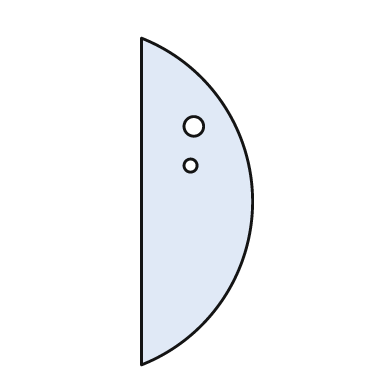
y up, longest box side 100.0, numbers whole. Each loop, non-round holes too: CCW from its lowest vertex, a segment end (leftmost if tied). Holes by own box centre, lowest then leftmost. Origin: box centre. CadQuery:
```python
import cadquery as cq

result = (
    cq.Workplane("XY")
    .moveTo(-17.0, -50.0)
    .threePointArc((17.0, 0.0), (-17.0, 50.0))
    .close()
    .moveTo(-2.0, 11.0)
    .circle(2.0)
    .moveTo(-1.0, 23.0)
    .circle(3.0)
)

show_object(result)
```